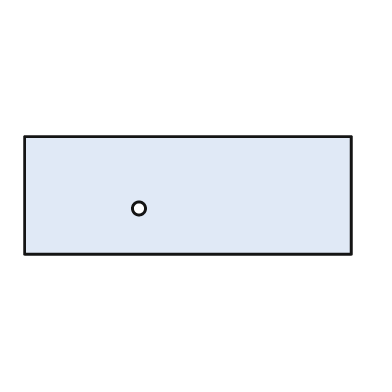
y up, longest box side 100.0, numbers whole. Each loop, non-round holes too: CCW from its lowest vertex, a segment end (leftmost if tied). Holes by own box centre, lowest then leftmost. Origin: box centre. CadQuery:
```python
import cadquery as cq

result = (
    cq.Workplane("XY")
    .moveTo(-50.0, -18.0)
    .lineTo(50.0, -18.0)
    .lineTo(50.0, 18.0)
    .lineTo(-50.0, 18.0)
    .close()
    .moveTo(-15.0, -4.0)
    .circle(2.0)
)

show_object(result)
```